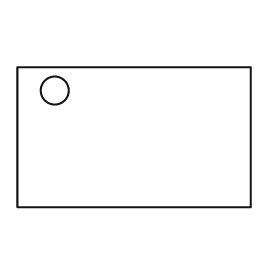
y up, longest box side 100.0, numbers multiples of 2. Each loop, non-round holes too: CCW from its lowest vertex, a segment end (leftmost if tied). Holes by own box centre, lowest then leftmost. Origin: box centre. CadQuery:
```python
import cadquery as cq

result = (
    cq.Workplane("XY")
    .moveTo(-50.0, -30.0)
    .lineTo(50.0, -30.0)
    .lineTo(50.0, 30.0)
    .lineTo(-50.0, 30.0)
    .close()
    .moveTo(-34.0, 20.0)
    .circle(6.0)
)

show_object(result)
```